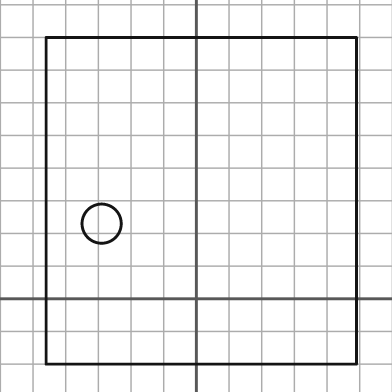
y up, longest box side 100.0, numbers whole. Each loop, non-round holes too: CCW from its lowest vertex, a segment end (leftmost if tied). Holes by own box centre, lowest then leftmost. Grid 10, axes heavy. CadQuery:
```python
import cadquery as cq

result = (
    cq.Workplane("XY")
    .moveTo(-46.0, -20.0)
    .lineTo(49.0, -20.0)
    .lineTo(49.0, 80.0)
    .lineTo(-46.0, 80.0)
    .close()
    .moveTo(-29.0, 23.0)
    .circle(6.0)
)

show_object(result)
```